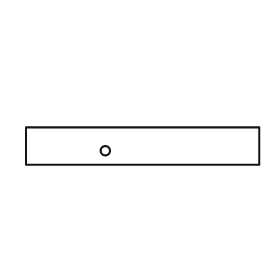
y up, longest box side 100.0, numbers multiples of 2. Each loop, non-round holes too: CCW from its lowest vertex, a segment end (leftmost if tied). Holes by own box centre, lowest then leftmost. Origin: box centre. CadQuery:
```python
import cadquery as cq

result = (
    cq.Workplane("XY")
    .moveTo(-50.0, -8.0)
    .lineTo(50.0, -8.0)
    .lineTo(50.0, 8.0)
    .lineTo(-50.0, 8.0)
    .close()
    .moveTo(-16.0, -2.0)
    .circle(2.0)
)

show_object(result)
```